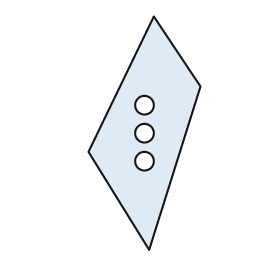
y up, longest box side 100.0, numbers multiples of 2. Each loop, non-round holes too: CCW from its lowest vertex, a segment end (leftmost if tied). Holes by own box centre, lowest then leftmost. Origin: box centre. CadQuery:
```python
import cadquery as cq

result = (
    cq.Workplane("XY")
    .moveTo(2.0, -50.0)
    .lineTo(24.0, 20.0)
    .lineTo(4.0, 50.0)
    .lineTo(-24.0, -8.0)
    .close()
    .moveTo(0.0, -12.0)
    .circle(4.0)
    .moveTo(0.0, 0.0)
    .circle(4.0)
    .moveTo(0.0, 12.0)
    .circle(4.0)
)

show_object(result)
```